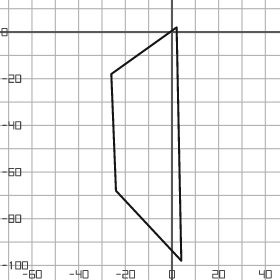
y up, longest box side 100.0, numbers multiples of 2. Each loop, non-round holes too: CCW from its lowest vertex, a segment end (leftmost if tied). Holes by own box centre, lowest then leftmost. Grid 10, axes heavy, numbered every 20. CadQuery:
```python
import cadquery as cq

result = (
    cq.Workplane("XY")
    .moveTo(4.0, -98.0)
    .lineTo(2.0, 2.0)
    .lineTo(-26.0, -18.0)
    .lineTo(-24.0, -68.0)
    .close()
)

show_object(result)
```